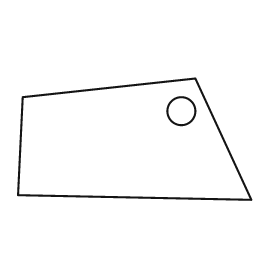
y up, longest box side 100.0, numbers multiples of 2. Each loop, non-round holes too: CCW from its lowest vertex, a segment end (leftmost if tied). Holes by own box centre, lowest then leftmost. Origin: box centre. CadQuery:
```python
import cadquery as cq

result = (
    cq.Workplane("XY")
    .moveTo(50.0, -26.0)
    .lineTo(26.0, 26.0)
    .lineTo(-48.0, 18.0)
    .lineTo(-50.0, -24.0)
    .close()
    .moveTo(20.0, 12.0)
    .circle(6.0)
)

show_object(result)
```